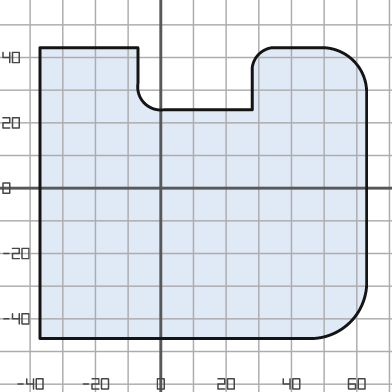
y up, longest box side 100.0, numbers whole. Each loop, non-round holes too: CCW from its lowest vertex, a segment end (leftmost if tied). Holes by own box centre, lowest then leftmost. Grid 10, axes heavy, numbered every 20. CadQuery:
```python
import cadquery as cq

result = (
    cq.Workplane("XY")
    .moveTo(-37.0, -46.0)
    .lineTo(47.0, -46.0)
    .threePointArc((58.0, -41.0), (63.0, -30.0))
    .lineTo(63.0, 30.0)
    .threePointArc((59.0, 39.0), (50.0, 43.0))
    .lineTo(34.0, 43.0)
    .threePointArc((30.0, 41.0), (28.0, 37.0))
    .lineTo(28.0, 24.0)
    .lineTo(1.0, 24.0)
    .threePointArc((-5.0, 26.0), (-7.0, 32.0))
    .lineTo(-7.0, 43.0)
    .lineTo(-37.0, 43.0)
    .close()
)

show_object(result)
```